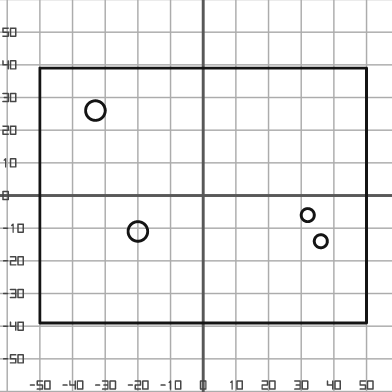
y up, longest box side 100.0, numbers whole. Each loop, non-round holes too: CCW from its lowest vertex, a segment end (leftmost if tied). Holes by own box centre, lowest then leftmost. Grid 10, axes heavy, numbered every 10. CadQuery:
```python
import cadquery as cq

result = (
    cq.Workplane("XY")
    .moveTo(-50.0, -39.0)
    .lineTo(50.0, -39.0)
    .lineTo(50.0, 39.0)
    .lineTo(-50.0, 39.0)
    .close()
    .moveTo(36.0, -14.0)
    .circle(2.0)
    .moveTo(-20.0, -11.0)
    .circle(3.0)
    .moveTo(32.0, -6.0)
    .circle(2.0)
    .moveTo(-33.0, 26.0)
    .circle(3.0)
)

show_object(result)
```